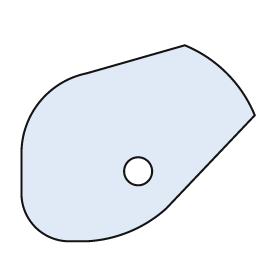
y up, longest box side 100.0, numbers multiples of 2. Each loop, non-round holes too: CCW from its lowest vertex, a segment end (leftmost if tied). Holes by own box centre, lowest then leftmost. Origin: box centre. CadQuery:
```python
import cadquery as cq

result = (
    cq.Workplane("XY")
    .moveTo(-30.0, -42.0)
    .lineTo(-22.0, -42.0)
    .threePointArc((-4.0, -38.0), (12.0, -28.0))
    .lineTo(50.0, 12.0)
    .threePointArc((38.0, 30.0), (20.0, 42.0))
    .lineTo(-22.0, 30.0)
    .threePointArc((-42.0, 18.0), (-50.0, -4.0))
    .lineTo(-50.0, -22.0)
    .threePointArc((-44.0, -36.0), (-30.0, -42.0))
    .close()
    .moveTo(0.0, -12.0)
    .circle(6.0)
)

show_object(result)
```